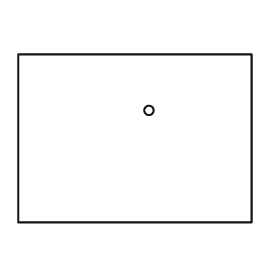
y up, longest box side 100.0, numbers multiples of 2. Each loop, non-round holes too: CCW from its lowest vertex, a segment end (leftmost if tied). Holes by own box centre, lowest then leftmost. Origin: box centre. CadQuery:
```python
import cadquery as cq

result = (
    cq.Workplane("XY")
    .moveTo(-50.0, -36.0)
    .lineTo(50.0, -36.0)
    .lineTo(50.0, 36.0)
    .lineTo(-50.0, 36.0)
    .close()
    .moveTo(6.0, 12.0)
    .circle(2.0)
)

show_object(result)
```